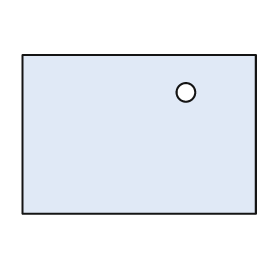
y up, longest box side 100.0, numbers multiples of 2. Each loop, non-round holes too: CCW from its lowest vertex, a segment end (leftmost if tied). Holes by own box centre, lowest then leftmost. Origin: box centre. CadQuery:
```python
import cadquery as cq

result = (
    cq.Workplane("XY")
    .moveTo(-50.0, -34.0)
    .lineTo(50.0, -34.0)
    .lineTo(50.0, 34.0)
    .lineTo(-50.0, 34.0)
    .close()
    .moveTo(20.0, 18.0)
    .circle(4.0)
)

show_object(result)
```